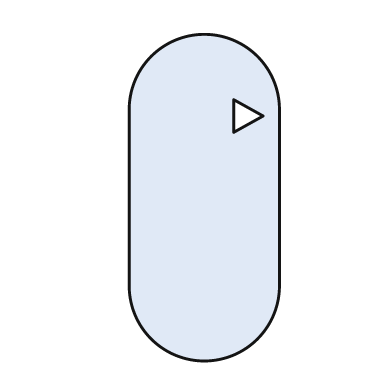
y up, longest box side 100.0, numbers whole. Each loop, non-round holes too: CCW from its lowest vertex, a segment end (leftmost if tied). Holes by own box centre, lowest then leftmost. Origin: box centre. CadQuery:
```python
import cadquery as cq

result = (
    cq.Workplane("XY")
    .moveTo(-23.0, -27.0)
    .threePointArc((0.0, -50.0), (23.0, -27.0))
    .lineTo(23.0, 27.0)
    .threePointArc((0.0, 50.0), (-23.0, 27.0))
    .close()
    .moveTo(9.0, 20.0)
    .lineTo(18.0, 25.0)
    .lineTo(9.0, 30.0)
    .close()
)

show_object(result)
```